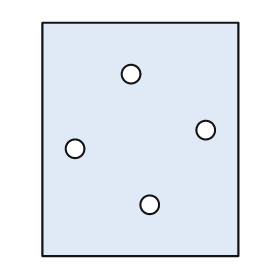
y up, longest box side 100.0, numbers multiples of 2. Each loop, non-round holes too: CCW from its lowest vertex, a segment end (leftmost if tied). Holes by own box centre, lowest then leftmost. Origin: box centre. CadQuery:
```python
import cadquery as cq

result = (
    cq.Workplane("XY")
    .moveTo(-42.0, -50.0)
    .lineTo(42.0, -50.0)
    .lineTo(42.0, 50.0)
    .lineTo(-42.0, 50.0)
    .close()
    .moveTo(4.0, -28.0)
    .circle(4.0)
    .moveTo(-28.0, -4.0)
    .circle(4.0)
    .moveTo(28.0, 4.0)
    .circle(4.0)
    .moveTo(-4.0, 28.0)
    .circle(4.0)
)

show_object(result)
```